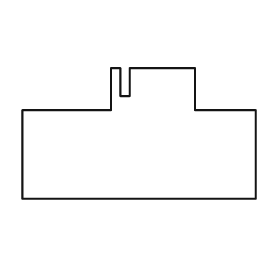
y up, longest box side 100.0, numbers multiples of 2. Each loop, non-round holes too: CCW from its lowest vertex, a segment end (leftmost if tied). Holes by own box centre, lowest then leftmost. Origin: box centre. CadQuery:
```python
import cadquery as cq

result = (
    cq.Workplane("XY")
    .moveTo(-50.0, -28.0)
    .lineTo(50.0, -28.0)
    .lineTo(50.0, 10.0)
    .lineTo(24.0, 10.0)
    .lineTo(24.0, 28.0)
    .lineTo(-4.0, 28.0)
    .lineTo(-4.0, 16.0)
    .lineTo(-8.0, 16.0)
    .lineTo(-8.0, 28.0)
    .lineTo(-12.0, 28.0)
    .lineTo(-12.0, 10.0)
    .lineTo(-50.0, 10.0)
    .close()
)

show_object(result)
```